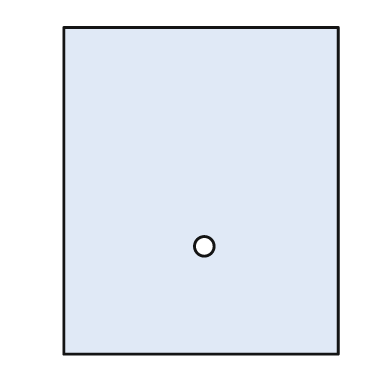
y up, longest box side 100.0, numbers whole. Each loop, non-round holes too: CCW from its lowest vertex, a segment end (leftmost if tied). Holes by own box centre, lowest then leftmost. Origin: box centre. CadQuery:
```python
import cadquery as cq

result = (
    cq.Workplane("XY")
    .moveTo(-42.0, -50.0)
    .lineTo(42.0, -50.0)
    .lineTo(42.0, 50.0)
    .lineTo(-42.0, 50.0)
    .close()
    .moveTo(1.0, -17.0)
    .circle(3.0)
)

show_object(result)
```